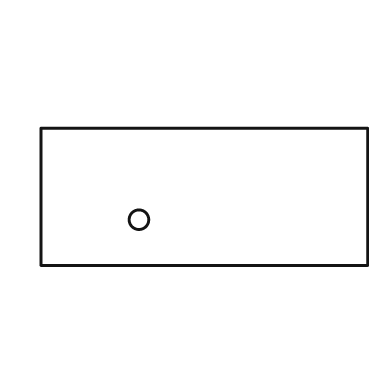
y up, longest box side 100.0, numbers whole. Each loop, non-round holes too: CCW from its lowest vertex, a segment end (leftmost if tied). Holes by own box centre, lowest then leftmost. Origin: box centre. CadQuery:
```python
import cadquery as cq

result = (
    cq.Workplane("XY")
    .moveTo(-50.0, -21.0)
    .lineTo(50.0, -21.0)
    .lineTo(50.0, 21.0)
    .lineTo(-50.0, 21.0)
    .close()
    .moveTo(-20.0, -7.0)
    .circle(3.0)
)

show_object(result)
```